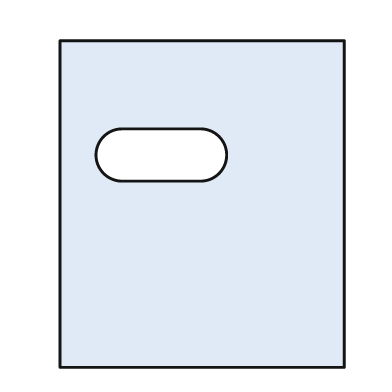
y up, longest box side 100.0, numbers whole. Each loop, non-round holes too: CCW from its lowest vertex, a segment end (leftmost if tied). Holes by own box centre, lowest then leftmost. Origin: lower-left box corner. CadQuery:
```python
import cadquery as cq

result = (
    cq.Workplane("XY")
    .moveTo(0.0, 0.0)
    .lineTo(87.0, 0.0)
    .lineTo(87.0, 100.0)
    .lineTo(0.0, 100.0)
    .close()
    .moveTo(19.0, 57.0)
    .lineTo(43.0, 57.0)
    .threePointArc((51.0, 65.0), (43.0, 73.0))
    .lineTo(19.0, 73.0)
    .threePointArc((11.0, 65.0), (19.0, 57.0))
    .close()
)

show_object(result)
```